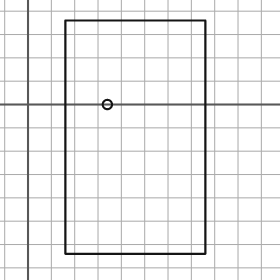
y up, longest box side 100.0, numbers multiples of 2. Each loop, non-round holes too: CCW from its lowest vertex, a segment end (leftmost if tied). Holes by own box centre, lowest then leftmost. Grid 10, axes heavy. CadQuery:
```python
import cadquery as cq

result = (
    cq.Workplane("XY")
    .moveTo(16.0, -64.0)
    .lineTo(76.0, -64.0)
    .lineTo(76.0, 36.0)
    .lineTo(16.0, 36.0)
    .close()
    .moveTo(34.0, 0.0)
    .circle(2.0)
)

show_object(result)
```